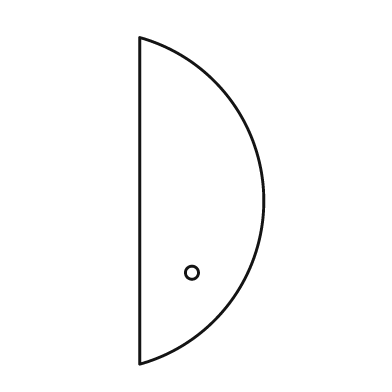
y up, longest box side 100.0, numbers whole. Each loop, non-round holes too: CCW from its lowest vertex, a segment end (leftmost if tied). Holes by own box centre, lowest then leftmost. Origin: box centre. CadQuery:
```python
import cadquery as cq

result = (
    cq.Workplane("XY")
    .moveTo(-19.0, -50.0)
    .threePointArc((19.0, 0.0), (-19.0, 50.0))
    .close()
    .moveTo(-3.0, -22.0)
    .circle(2.0)
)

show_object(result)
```